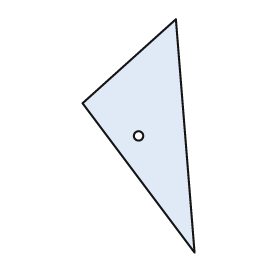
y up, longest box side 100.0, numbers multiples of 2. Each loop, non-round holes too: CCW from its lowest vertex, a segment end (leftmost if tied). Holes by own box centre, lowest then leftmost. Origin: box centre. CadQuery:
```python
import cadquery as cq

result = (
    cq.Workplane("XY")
    .moveTo(24.0, -50.0)
    .lineTo(16.0, 50.0)
    .lineTo(-24.0, 14.0)
    .close()
    .moveTo(0.0, 0.0)
    .circle(2.0)
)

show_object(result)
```